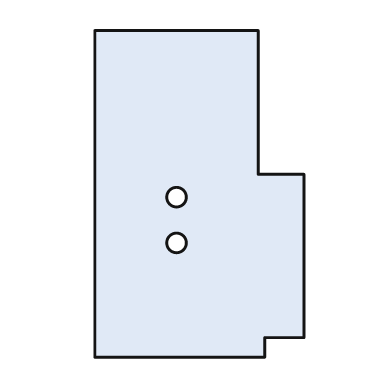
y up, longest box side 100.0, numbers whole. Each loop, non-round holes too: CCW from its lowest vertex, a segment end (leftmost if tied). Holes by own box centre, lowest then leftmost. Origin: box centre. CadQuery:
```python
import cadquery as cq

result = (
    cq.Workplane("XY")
    .moveTo(-32.0, -50.0)
    .lineTo(20.0, -50.0)
    .lineTo(20.0, -44.0)
    .lineTo(32.0, -44.0)
    .lineTo(32.0, 6.0)
    .lineTo(18.0, 6.0)
    .lineTo(18.0, 50.0)
    .lineTo(-32.0, 50.0)
    .close()
    .moveTo(-7.0, -15.0)
    .circle(3.0)
    .moveTo(-7.0, -1.0)
    .circle(3.0)
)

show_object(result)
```